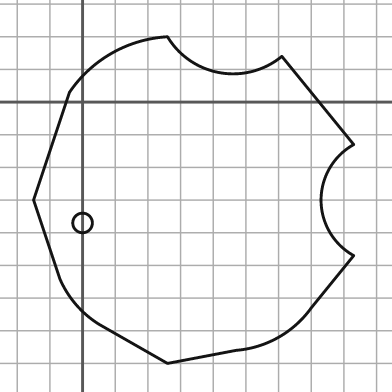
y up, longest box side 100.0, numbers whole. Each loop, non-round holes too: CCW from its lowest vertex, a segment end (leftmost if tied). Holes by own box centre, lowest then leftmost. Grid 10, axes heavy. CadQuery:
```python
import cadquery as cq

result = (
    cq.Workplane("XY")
    .moveTo(26.0, -80.0)
    .lineTo(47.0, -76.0)
    .threePointArc((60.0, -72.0), (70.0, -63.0))
    .lineTo(83.0, -47.0)
    .threePointArc((73.0, -30.0), (83.0, -13.0))
    .lineTo(61.0, 14.0)
    .threePointArc((42.0, 9.0), (26.0, 20.0))
    .threePointArc((9.0, 15.0), (-4.0, 3.0))
    .lineTo(-15.0, -30.0)
    .lineTo(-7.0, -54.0)
    .threePointArc((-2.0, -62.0), (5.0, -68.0))
    .close()
    .moveTo(0.0, -37.0)
    .circle(3.0)
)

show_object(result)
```